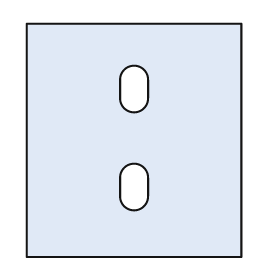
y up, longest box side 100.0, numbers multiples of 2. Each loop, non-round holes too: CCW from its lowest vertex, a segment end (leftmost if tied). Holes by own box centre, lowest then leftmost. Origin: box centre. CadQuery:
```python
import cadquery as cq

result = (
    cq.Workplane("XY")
    .moveTo(-46.0, -50.0)
    .lineTo(46.0, -50.0)
    .lineTo(46.0, 50.0)
    .lineTo(-46.0, 50.0)
    .close()
    .moveTo(-6.0, -24.0)
    .threePointArc((0.0, -30.0), (6.0, -24.0))
    .lineTo(6.0, -16.0)
    .threePointArc((0.0, -10.0), (-6.0, -16.0))
    .close()
    .moveTo(-6.0, 18.0)
    .threePointArc((0.0, 12.0), (6.0, 18.0))
    .lineTo(6.0, 26.0)
    .threePointArc((0.0, 32.0), (-6.0, 26.0))
    .close()
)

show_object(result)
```